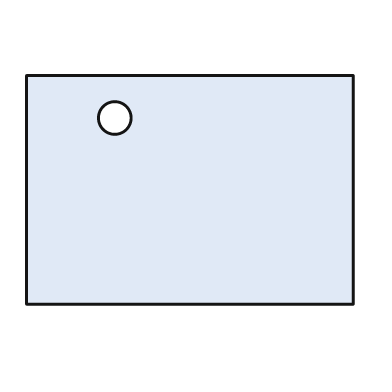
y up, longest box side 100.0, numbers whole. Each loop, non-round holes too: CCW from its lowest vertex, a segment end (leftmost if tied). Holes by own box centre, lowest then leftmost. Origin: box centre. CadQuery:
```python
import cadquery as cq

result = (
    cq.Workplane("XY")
    .moveTo(-50.0, -35.0)
    .lineTo(50.0, -35.0)
    .lineTo(50.0, 35.0)
    .lineTo(-50.0, 35.0)
    .close()
    .moveTo(-23.0, 22.0)
    .circle(5.0)
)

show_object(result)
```